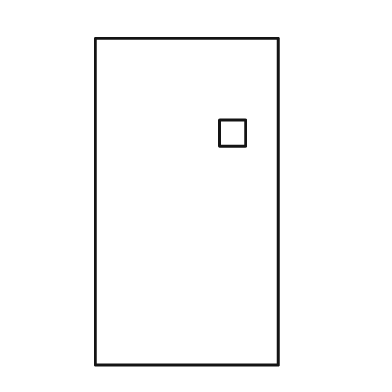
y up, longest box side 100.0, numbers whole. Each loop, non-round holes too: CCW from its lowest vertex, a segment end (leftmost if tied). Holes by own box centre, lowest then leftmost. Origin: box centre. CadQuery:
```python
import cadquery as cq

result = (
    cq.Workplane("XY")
    .moveTo(-28.0, -50.0)
    .lineTo(28.0, -50.0)
    .lineTo(28.0, 50.0)
    .lineTo(-28.0, 50.0)
    .close()
    .moveTo(10.0, 17.0)
    .lineTo(18.0, 17.0)
    .lineTo(18.0, 25.0)
    .lineTo(10.0, 25.0)
    .close()
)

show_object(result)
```